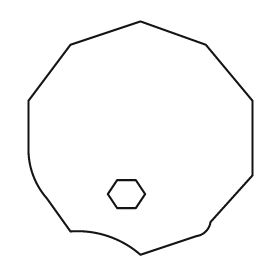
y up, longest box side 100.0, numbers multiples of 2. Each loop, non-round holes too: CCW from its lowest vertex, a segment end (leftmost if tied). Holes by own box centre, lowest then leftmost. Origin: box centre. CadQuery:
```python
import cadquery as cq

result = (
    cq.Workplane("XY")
    .moveTo(0.0, -50.0)
    .lineTo(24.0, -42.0)
    .threePointArc((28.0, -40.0), (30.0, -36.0))
    .lineTo(48.0, -16.0)
    .lineTo(48.0, 16.0)
    .lineTo(28.0, 40.0)
    .lineTo(0.0, 50.0)
    .lineTo(-30.0, 40.0)
    .lineTo(-48.0, 16.0)
    .lineTo(-48.0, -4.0)
    .threePointArc((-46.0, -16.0), (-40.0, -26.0))
    .lineTo(-30.0, -40.0)
    .threePointArc((-14.0, -42.0), (0.0, -50.0))
    .close()
    .moveTo(-10.0, -30.0)
    .lineTo(-2.0, -30.0)
    .lineTo(2.0, -24.0)
    .lineTo(-2.0, -18.0)
    .lineTo(-10.0, -18.0)
    .lineTo(-14.0, -24.0)
    .close()
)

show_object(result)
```